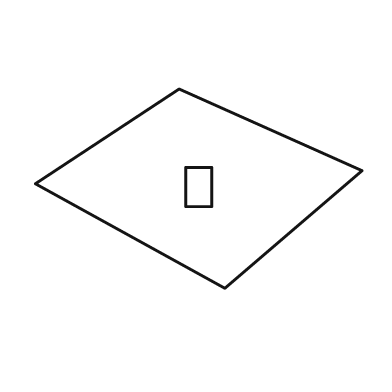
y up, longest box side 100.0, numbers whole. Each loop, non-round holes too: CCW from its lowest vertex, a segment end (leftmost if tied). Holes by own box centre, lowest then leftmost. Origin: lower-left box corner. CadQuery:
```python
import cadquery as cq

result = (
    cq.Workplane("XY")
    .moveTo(58.0, 0.0)
    .lineTo(100.0, 36.0)
    .lineTo(44.0, 61.0)
    .lineTo(0.0, 32.0)
    .close()
    .moveTo(46.0, 25.0)
    .lineTo(54.0, 25.0)
    .lineTo(54.0, 37.0)
    .lineTo(46.0, 37.0)
    .close()
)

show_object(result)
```